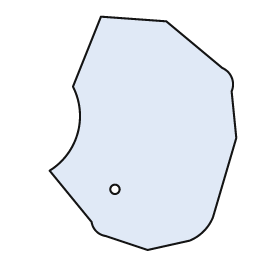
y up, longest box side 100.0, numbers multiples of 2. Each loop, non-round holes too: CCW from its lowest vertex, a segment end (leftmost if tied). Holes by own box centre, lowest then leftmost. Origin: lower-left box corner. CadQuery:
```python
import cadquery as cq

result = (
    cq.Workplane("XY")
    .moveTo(42.0, 0.0)
    .lineTo(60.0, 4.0)
    .threePointArc((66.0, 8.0), (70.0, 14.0))
    .lineTo(80.0, 48.0)
    .lineTo(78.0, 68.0)
    .threePointArc((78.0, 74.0), (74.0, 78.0))
    .lineTo(50.0, 98.0)
    .lineTo(22.0, 100.0)
    .lineTo(10.0, 70.0)
    .threePointArc((12.0, 50.0), (0.0, 34.0))
    .lineTo(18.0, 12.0)
    .threePointArc((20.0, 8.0), (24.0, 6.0))
    .close()
    .moveTo(28.0, 26.0)
    .circle(2.0)
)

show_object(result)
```